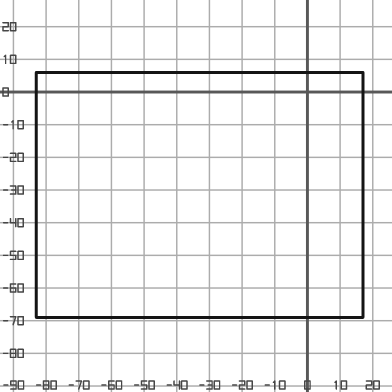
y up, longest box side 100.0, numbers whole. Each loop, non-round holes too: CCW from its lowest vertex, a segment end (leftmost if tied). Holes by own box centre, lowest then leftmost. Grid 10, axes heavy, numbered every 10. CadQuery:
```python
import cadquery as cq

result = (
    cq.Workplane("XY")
    .moveTo(-83.0, -69.0)
    .lineTo(17.0, -69.0)
    .lineTo(17.0, 6.0)
    .lineTo(-83.0, 6.0)
    .close()
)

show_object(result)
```